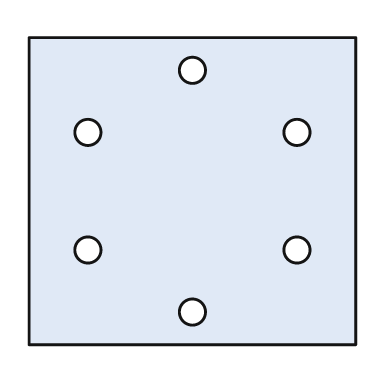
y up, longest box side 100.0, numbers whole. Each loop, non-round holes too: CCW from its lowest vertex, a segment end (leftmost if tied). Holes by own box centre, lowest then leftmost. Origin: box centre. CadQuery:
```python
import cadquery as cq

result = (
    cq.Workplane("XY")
    .moveTo(-50.0, -47.0)
    .lineTo(50.0, -47.0)
    .lineTo(50.0, 47.0)
    .lineTo(-50.0, 47.0)
    .close()
    .moveTo(0.0, -37.0)
    .circle(4.0)
    .moveTo(-32.0, -18.0)
    .circle(4.0)
    .moveTo(32.0, -18.0)
    .circle(4.0)
    .moveTo(-32.0, 18.0)
    .circle(4.0)
    .moveTo(32.0, 18.0)
    .circle(4.0)
    .moveTo(0.0, 37.0)
    .circle(4.0)
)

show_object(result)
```